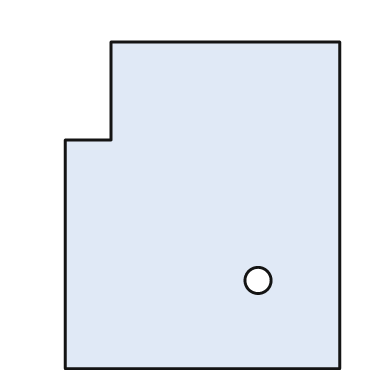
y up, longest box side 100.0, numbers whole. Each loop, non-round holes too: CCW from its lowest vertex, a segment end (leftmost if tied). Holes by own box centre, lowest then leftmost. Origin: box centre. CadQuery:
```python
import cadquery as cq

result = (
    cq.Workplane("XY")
    .moveTo(-42.0, -50.0)
    .lineTo(42.0, -50.0)
    .lineTo(42.0, 50.0)
    .lineTo(-28.0, 50.0)
    .lineTo(-28.0, 20.0)
    .lineTo(-42.0, 20.0)
    .close()
    .moveTo(17.0, -23.0)
    .circle(4.0)
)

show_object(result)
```